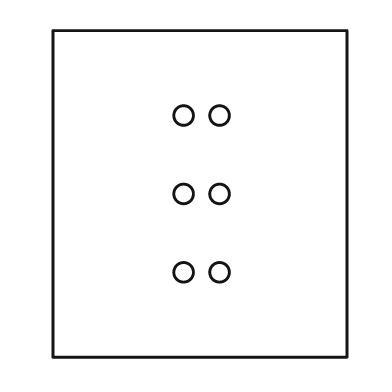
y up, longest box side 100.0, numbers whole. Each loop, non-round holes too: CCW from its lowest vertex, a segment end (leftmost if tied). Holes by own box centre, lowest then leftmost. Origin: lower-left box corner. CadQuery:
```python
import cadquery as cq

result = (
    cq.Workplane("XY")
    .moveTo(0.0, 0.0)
    .lineTo(90.0, 0.0)
    .lineTo(90.0, 100.0)
    .lineTo(0.0, 100.0)
    .close()
    .moveTo(40.0, 26.0)
    .circle(3.0)
    .moveTo(51.0, 26.0)
    .circle(3.0)
    .moveTo(40.0, 50.0)
    .circle(3.0)
    .moveTo(51.0, 50.0)
    .circle(3.0)
    .moveTo(40.0, 74.0)
    .circle(3.0)
    .moveTo(51.0, 74.0)
    .circle(3.0)
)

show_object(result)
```